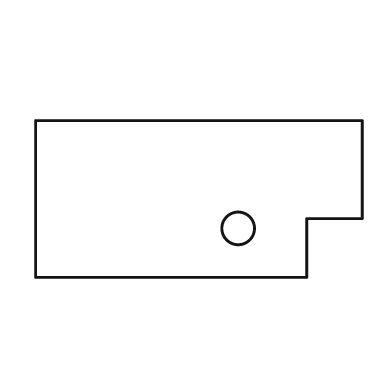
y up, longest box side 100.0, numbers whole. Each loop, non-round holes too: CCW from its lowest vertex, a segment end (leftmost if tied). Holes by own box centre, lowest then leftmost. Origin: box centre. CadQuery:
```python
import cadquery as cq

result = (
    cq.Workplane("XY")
    .moveTo(-50.0, -24.0)
    .lineTo(33.0, -24.0)
    .lineTo(33.0, -6.0)
    .lineTo(50.0, -6.0)
    .lineTo(50.0, 24.0)
    .lineTo(-50.0, 24.0)
    .close()
    .moveTo(12.0, -9.0)
    .circle(5.0)
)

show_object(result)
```